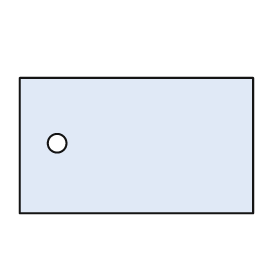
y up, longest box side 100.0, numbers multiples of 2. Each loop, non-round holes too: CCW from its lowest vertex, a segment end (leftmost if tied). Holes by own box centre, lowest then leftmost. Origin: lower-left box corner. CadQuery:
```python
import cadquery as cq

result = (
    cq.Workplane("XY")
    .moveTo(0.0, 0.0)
    .lineTo(100.0, 0.0)
    .lineTo(100.0, 58.0)
    .lineTo(0.0, 58.0)
    .close()
    .moveTo(16.0, 30.0)
    .circle(4.0)
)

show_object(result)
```